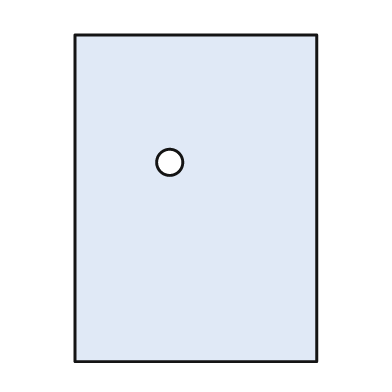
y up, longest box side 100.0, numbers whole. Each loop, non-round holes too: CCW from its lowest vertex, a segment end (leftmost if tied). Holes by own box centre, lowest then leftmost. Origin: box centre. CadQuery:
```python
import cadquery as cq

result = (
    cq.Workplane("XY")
    .moveTo(-37.0, -50.0)
    .lineTo(37.0, -50.0)
    .lineTo(37.0, 50.0)
    .lineTo(-37.0, 50.0)
    .close()
    .moveTo(-8.0, 11.0)
    .circle(4.0)
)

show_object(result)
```